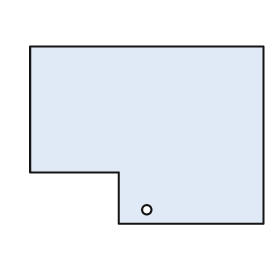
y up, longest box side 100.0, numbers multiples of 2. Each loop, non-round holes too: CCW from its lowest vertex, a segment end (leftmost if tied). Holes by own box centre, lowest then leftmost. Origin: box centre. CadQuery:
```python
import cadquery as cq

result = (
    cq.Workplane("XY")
    .moveTo(-12.0, -38.0)
    .lineTo(50.0, -38.0)
    .lineTo(50.0, 38.0)
    .lineTo(-50.0, 38.0)
    .lineTo(-50.0, -16.0)
    .lineTo(-12.0, -16.0)
    .close()
    .moveTo(0.0, -32.0)
    .circle(2.0)
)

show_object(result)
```